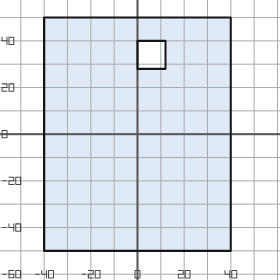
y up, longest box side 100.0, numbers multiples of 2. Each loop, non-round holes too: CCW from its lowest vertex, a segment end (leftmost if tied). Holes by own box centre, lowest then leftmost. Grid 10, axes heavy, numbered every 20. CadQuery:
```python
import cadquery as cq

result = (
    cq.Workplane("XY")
    .moveTo(-40.0, -50.0)
    .lineTo(40.0, -50.0)
    .lineTo(40.0, 50.0)
    .lineTo(-40.0, 50.0)
    .close()
    .moveTo(0.0, 28.0)
    .lineTo(12.0, 28.0)
    .lineTo(12.0, 40.0)
    .lineTo(0.0, 40.0)
    .close()
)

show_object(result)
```